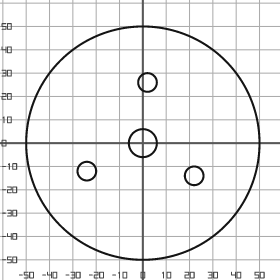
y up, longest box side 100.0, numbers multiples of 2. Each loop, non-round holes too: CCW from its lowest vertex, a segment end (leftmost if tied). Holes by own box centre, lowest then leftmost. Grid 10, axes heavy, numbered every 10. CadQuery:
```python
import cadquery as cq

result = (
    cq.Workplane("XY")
    .moveTo(0.0, 0.0)
    .circle(50.0)
    .moveTo(22.0, -14.0)
    .circle(4.0)
    .moveTo(-24.0, -12.0)
    .circle(4.0)
    .moveTo(0.0, 0.0)
    .circle(6.0)
    .moveTo(2.0, 26.0)
    .circle(4.0)
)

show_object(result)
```